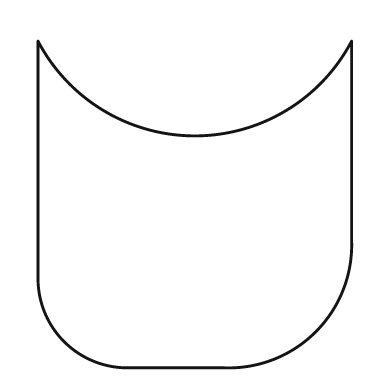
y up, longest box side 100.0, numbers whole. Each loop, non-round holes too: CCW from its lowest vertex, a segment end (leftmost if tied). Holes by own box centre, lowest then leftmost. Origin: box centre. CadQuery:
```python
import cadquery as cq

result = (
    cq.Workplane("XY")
    .moveTo(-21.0, -50.0)
    .lineTo(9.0, -50.0)
    .threePointArc((37.0, -39.0), (48.0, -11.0))
    .lineTo(48.0, 50.0)
    .threePointArc((0.0, 21.0), (-48.0, 50.0))
    .lineTo(-48.0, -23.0)
    .threePointArc((-40.0, -42.0), (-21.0, -50.0))
    .close()
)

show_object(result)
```